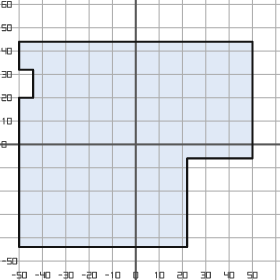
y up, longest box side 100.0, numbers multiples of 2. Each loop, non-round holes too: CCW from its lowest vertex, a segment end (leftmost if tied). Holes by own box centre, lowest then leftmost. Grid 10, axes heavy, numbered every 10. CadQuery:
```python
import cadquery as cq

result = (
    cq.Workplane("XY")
    .moveTo(-50.0, -44.0)
    .lineTo(22.0, -44.0)
    .lineTo(22.0, -6.0)
    .lineTo(50.0, -6.0)
    .lineTo(50.0, 44.0)
    .lineTo(-50.0, 44.0)
    .lineTo(-50.0, 32.0)
    .lineTo(-44.0, 32.0)
    .lineTo(-44.0, 20.0)
    .lineTo(-50.0, 20.0)
    .close()
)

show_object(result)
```